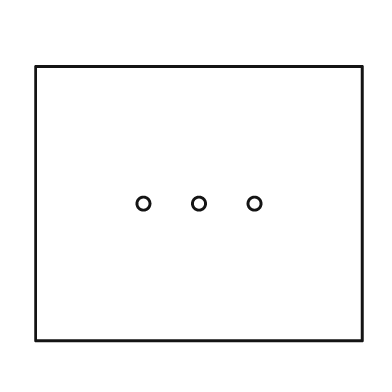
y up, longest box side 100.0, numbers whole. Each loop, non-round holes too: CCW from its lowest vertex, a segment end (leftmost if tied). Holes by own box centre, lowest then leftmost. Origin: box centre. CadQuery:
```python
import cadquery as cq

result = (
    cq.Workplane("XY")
    .moveTo(-50.0, -42.0)
    .lineTo(50.0, -42.0)
    .lineTo(50.0, 42.0)
    .lineTo(-50.0, 42.0)
    .close()
    .moveTo(-17.0, 0.0)
    .circle(2.0)
    .moveTo(0.0, 0.0)
    .circle(2.0)
    .moveTo(17.0, 0.0)
    .circle(2.0)
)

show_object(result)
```